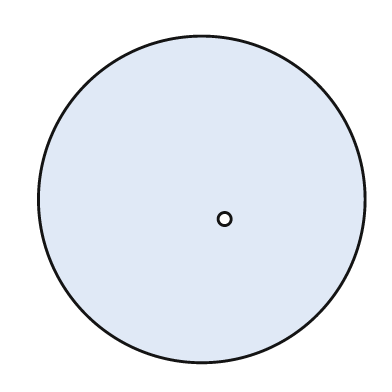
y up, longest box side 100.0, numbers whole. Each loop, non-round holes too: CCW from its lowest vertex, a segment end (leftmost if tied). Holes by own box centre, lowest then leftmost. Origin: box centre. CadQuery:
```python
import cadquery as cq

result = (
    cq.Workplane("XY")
    .moveTo(0.0, 0.0)
    .circle(50.0)
    .moveTo(7.0, -6.0)
    .circle(2.0)
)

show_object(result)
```